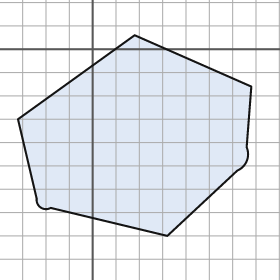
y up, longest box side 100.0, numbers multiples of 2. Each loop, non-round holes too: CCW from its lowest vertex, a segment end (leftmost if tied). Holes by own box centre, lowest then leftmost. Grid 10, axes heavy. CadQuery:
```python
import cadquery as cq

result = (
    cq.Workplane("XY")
    .moveTo(32.0, -80.0)
    .lineTo(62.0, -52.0)
    .threePointArc((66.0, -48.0), (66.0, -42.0))
    .lineTo(68.0, -16.0)
    .lineTo(18.0, 6.0)
    .lineTo(-32.0, -30.0)
    .lineTo(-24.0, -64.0)
    .threePointArc((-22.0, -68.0), (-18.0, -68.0))
    .close()
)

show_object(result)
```